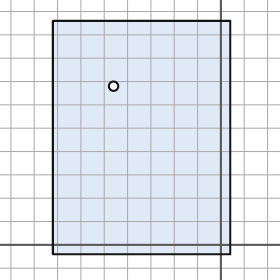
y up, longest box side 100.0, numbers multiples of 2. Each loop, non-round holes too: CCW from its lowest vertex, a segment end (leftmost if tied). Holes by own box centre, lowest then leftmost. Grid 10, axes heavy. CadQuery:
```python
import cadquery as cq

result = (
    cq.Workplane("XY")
    .moveTo(-72.0, -4.0)
    .lineTo(4.0, -4.0)
    .lineTo(4.0, 96.0)
    .lineTo(-72.0, 96.0)
    .close()
    .moveTo(-46.0, 68.0)
    .circle(2.0)
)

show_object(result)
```